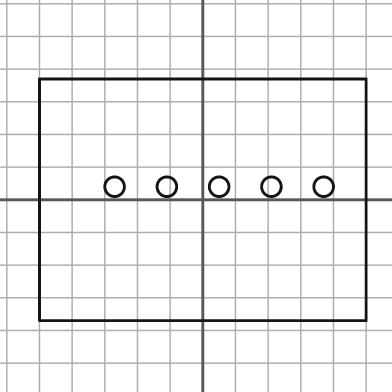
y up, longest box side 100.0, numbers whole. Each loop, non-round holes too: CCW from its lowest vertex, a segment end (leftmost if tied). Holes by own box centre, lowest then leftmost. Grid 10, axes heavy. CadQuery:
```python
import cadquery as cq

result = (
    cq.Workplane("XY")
    .moveTo(-50.0, -37.0)
    .lineTo(50.0, -37.0)
    .lineTo(50.0, 37.0)
    .lineTo(-50.0, 37.0)
    .close()
    .moveTo(-27.0, 4.0)
    .circle(3.0)
    .moveTo(-11.0, 4.0)
    .circle(3.0)
    .moveTo(5.0, 4.0)
    .circle(3.0)
    .moveTo(21.0, 4.0)
    .circle(3.0)
    .moveTo(37.0, 4.0)
    .circle(3.0)
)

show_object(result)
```